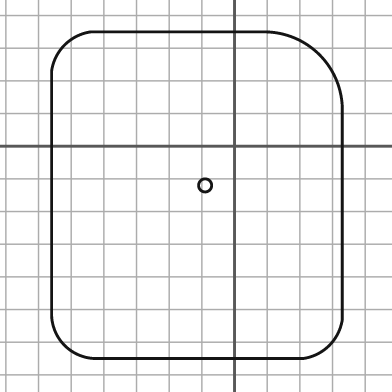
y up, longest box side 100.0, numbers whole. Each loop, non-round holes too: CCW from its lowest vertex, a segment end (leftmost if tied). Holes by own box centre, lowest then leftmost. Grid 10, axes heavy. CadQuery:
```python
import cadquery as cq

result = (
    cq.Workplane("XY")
    .moveTo(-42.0, -65.0)
    .lineTo(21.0, -65.0)
    .threePointArc((29.0, -61.0), (33.0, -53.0))
    .lineTo(33.0, 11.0)
    .threePointArc((26.0, 28.0), (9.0, 35.0))
    .lineTo(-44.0, 35.0)
    .threePointArc((-52.0, 31.0), (-56.0, 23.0))
    .lineTo(-56.0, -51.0)
    .threePointArc((-52.0, -61.0), (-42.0, -65.0))
    .close()
    .moveTo(-9.0, -12.0)
    .circle(2.0)
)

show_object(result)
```